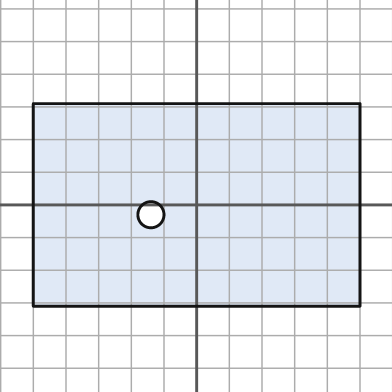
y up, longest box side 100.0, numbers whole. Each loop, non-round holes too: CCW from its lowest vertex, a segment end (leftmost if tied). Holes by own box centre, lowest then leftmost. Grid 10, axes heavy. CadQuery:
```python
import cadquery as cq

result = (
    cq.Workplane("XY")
    .moveTo(-50.0, -31.0)
    .lineTo(50.0, -31.0)
    .lineTo(50.0, 31.0)
    .lineTo(-50.0, 31.0)
    .close()
    .moveTo(-14.0, -3.0)
    .circle(4.0)
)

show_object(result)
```